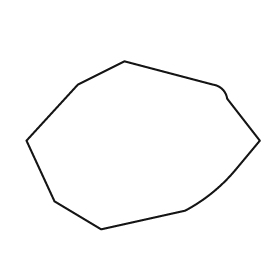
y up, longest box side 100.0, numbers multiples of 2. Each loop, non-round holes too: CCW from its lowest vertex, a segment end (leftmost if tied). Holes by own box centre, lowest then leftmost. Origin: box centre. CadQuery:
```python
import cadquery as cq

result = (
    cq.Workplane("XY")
    .moveTo(-18.0, -36.0)
    .lineTo(18.0, -28.0)
    .threePointArc((30.0, -20.0), (40.0, -10.0))
    .lineTo(50.0, 2.0)
    .lineTo(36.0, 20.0)
    .threePointArc((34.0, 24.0), (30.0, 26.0))
    .lineTo(-8.0, 36.0)
    .lineTo(-28.0, 26.0)
    .lineTo(-50.0, 2.0)
    .lineTo(-38.0, -24.0)
    .close()
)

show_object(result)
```